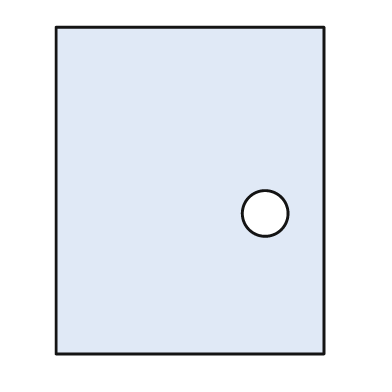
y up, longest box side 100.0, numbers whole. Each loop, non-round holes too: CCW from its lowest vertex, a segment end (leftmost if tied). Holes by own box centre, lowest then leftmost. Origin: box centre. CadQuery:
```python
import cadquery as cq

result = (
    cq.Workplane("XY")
    .moveTo(-41.0, -50.0)
    .lineTo(41.0, -50.0)
    .lineTo(41.0, 50.0)
    .lineTo(-41.0, 50.0)
    .close()
    .moveTo(23.0, -7.0)
    .circle(7.0)
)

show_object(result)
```